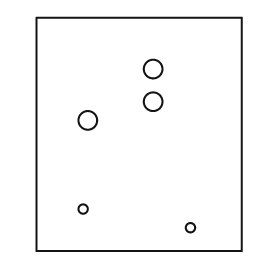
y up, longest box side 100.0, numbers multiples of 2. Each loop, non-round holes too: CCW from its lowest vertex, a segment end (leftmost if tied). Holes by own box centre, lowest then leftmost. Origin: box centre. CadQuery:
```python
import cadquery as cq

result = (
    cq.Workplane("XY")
    .moveTo(-44.0, -50.0)
    .lineTo(44.0, -50.0)
    .lineTo(44.0, 50.0)
    .lineTo(-44.0, 50.0)
    .close()
    .moveTo(22.0, -40.0)
    .circle(2.0)
    .moveTo(-24.0, -32.0)
    .circle(2.0)
    .moveTo(-22.0, 6.0)
    .circle(4.0)
    .moveTo(6.0, 14.0)
    .circle(4.0)
    .moveTo(6.0, 28.0)
    .circle(4.0)
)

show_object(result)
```